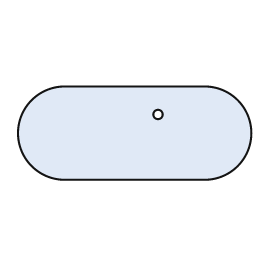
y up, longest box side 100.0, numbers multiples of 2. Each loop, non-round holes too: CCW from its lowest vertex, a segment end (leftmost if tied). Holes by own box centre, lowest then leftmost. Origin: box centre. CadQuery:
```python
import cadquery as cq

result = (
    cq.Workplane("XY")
    .moveTo(-30.0, -20.0)
    .lineTo(30.0, -20.0)
    .threePointArc((50.0, 0.0), (30.0, 20.0))
    .lineTo(-30.0, 20.0)
    .threePointArc((-50.0, 0.0), (-30.0, -20.0))
    .close()
    .moveTo(10.0, 8.0)
    .circle(2.0)
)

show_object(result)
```